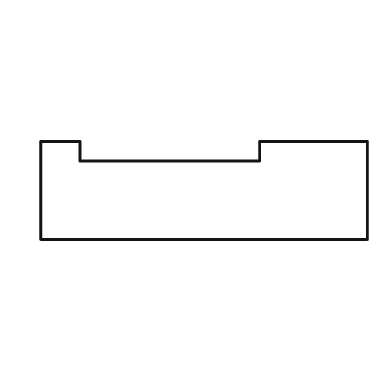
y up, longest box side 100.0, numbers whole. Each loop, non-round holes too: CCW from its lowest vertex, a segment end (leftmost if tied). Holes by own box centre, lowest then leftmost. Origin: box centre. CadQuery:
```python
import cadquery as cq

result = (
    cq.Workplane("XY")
    .moveTo(-50.0, -15.0)
    .lineTo(50.0, -15.0)
    .lineTo(50.0, 15.0)
    .lineTo(17.0, 15.0)
    .lineTo(17.0, 9.0)
    .lineTo(-38.0, 9.0)
    .lineTo(-38.0, 15.0)
    .lineTo(-50.0, 15.0)
    .close()
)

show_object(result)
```